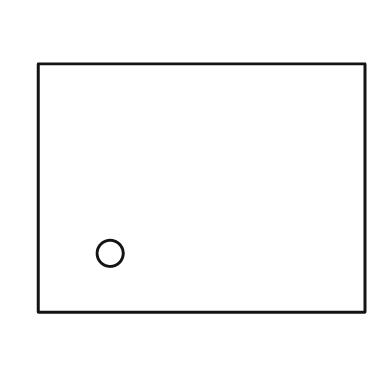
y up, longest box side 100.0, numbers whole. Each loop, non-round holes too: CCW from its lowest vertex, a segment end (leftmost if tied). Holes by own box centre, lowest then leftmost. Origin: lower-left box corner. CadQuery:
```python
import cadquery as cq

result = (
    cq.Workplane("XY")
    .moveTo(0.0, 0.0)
    .lineTo(100.0, 0.0)
    .lineTo(100.0, 76.0)
    .lineTo(0.0, 76.0)
    .close()
    .moveTo(22.0, 18.0)
    .circle(4.0)
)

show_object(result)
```